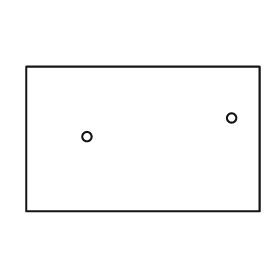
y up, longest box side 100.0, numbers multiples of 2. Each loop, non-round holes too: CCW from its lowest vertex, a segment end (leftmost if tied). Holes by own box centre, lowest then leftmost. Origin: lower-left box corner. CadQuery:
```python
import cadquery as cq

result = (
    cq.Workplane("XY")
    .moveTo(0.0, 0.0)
    .lineTo(100.0, 0.0)
    .lineTo(100.0, 62.0)
    .lineTo(0.0, 62.0)
    .close()
    .moveTo(26.0, 32.0)
    .circle(2.0)
    .moveTo(88.0, 40.0)
    .circle(2.0)
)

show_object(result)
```